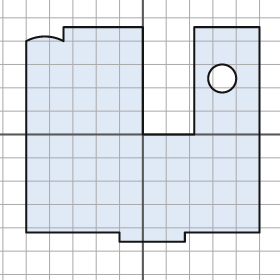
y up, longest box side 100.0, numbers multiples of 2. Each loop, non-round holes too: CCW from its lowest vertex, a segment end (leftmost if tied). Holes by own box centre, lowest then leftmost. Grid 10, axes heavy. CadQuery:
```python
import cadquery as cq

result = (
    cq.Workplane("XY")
    .moveTo(-10.0, -46.0)
    .lineTo(18.0, -46.0)
    .lineTo(18.0, -42.0)
    .lineTo(50.0, -42.0)
    .lineTo(50.0, 46.0)
    .lineTo(22.0, 46.0)
    .lineTo(22.0, 0.0)
    .lineTo(0.0, 0.0)
    .lineTo(0.0, 46.0)
    .lineTo(-34.0, 46.0)
    .lineTo(-34.0, 40.0)
    .threePointArc((-42.0, 42.0), (-50.0, 40.0))
    .lineTo(-50.0, -42.0)
    .lineTo(-10.0, -42.0)
    .close()
    .moveTo(34.0, 24.0)
    .circle(6.0)
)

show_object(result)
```